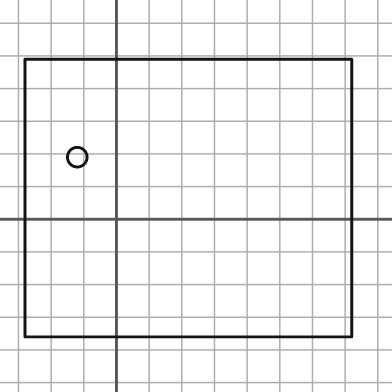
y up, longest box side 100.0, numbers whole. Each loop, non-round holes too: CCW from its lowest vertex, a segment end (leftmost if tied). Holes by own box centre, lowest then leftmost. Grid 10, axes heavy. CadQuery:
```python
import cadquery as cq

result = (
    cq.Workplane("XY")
    .moveTo(-28.0, -36.0)
    .lineTo(72.0, -36.0)
    .lineTo(72.0, 49.0)
    .lineTo(-28.0, 49.0)
    .close()
    .moveTo(-12.0, 19.0)
    .circle(3.0)
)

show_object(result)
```